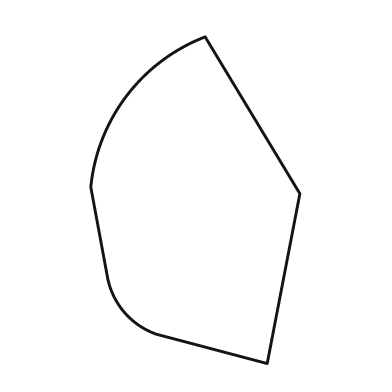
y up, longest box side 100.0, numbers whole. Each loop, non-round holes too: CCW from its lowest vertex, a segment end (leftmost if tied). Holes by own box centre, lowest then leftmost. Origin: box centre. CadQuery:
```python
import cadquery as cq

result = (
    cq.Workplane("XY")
    .moveTo(22.0, -50.0)
    .lineTo(32.0, 2.0)
    .lineTo(3.0, 50.0)
    .threePointArc((-21.0, 32.0), (-32.0, 4.0))
    .lineTo(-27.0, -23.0)
    .threePointArc((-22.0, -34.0), (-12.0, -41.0))
    .close()
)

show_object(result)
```